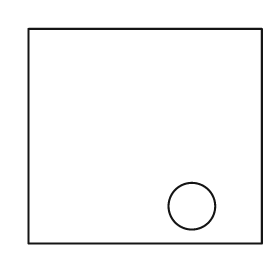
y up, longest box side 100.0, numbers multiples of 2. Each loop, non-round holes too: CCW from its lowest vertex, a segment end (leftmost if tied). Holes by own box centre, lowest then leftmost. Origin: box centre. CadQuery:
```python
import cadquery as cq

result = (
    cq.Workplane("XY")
    .moveTo(-50.0, -46.0)
    .lineTo(50.0, -46.0)
    .lineTo(50.0, 46.0)
    .lineTo(-50.0, 46.0)
    .close()
    .moveTo(20.0, -30.0)
    .circle(10.0)
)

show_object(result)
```